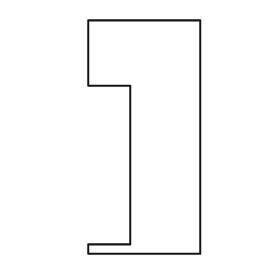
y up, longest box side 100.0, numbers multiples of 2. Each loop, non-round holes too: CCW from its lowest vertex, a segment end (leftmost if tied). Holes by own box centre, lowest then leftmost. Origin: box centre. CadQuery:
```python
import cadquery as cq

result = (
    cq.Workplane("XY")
    .moveTo(-24.0, -50.0)
    .lineTo(24.0, -50.0)
    .lineTo(24.0, 50.0)
    .lineTo(-24.0, 50.0)
    .lineTo(-24.0, 22.0)
    .lineTo(-6.0, 22.0)
    .lineTo(-6.0, -46.0)
    .lineTo(-24.0, -46.0)
    .close()
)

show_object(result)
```